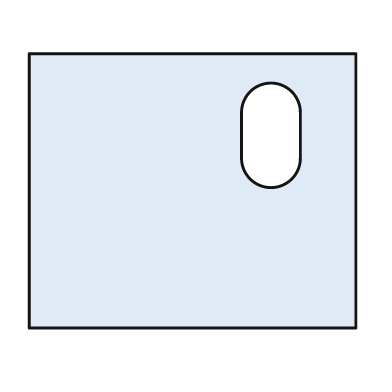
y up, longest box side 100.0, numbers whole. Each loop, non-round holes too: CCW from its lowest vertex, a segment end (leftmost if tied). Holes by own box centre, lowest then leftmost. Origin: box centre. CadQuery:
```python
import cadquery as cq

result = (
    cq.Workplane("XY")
    .moveTo(-50.0, -42.0)
    .lineTo(50.0, -42.0)
    .lineTo(50.0, 42.0)
    .lineTo(-50.0, 42.0)
    .close()
    .moveTo(15.0, 10.0)
    .threePointArc((24.0, 1.0), (33.0, 10.0))
    .lineTo(33.0, 24.0)
    .threePointArc((24.0, 33.0), (15.0, 24.0))
    .close()
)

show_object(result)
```